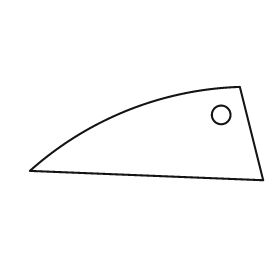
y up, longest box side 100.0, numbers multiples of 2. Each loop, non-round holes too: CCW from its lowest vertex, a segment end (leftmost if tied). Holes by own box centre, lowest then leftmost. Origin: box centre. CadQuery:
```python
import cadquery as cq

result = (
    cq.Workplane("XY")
    .moveTo(50.0, -20.0)
    .lineTo(40.0, 20.0)
    .threePointArc((-8.0, 10.0), (-50.0, -16.0))
    .close()
    .moveTo(32.0, 8.0)
    .circle(4.0)
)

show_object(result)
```